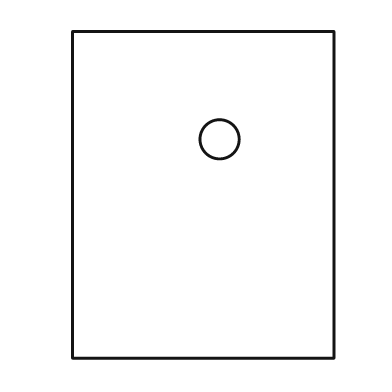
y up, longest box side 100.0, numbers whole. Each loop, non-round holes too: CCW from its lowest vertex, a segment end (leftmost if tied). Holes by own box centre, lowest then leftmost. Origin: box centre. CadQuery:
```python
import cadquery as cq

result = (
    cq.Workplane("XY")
    .moveTo(-40.0, -50.0)
    .lineTo(40.0, -50.0)
    .lineTo(40.0, 50.0)
    .lineTo(-40.0, 50.0)
    .close()
    .moveTo(5.0, 17.0)
    .circle(6.0)
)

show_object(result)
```